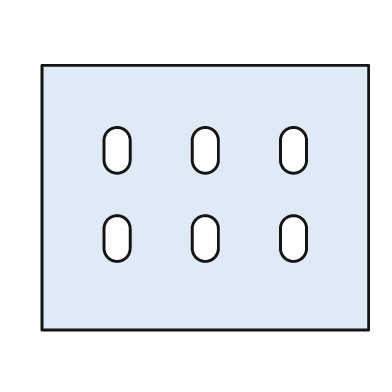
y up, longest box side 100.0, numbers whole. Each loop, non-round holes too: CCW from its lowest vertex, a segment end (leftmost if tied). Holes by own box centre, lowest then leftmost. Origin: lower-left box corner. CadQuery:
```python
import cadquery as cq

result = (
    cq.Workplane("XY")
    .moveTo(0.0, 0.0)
    .lineTo(100.0, 0.0)
    .lineTo(100.0, 81.0)
    .lineTo(0.0, 81.0)
    .close()
    .moveTo(19.0, 25.0)
    .threePointArc((23.0, 21.0), (27.0, 25.0))
    .lineTo(27.0, 31.0)
    .threePointArc((23.0, 35.0), (19.0, 31.0))
    .close()
    .moveTo(46.0, 25.0)
    .threePointArc((50.0, 21.0), (54.0, 25.0))
    .lineTo(54.0, 31.0)
    .threePointArc((50.0, 35.0), (46.0, 31.0))
    .close()
    .moveTo(73.0, 25.0)
    .threePointArc((77.0, 21.0), (81.0, 25.0))
    .lineTo(81.0, 31.0)
    .threePointArc((77.0, 35.0), (73.0, 31.0))
    .close()
    .moveTo(19.0, 52.0)
    .threePointArc((23.0, 48.0), (27.0, 52.0))
    .lineTo(27.0, 58.0)
    .threePointArc((23.0, 62.0), (19.0, 58.0))
    .close()
    .moveTo(46.0, 52.0)
    .threePointArc((50.0, 48.0), (54.0, 52.0))
    .lineTo(54.0, 58.0)
    .threePointArc((50.0, 62.0), (46.0, 58.0))
    .close()
    .moveTo(73.0, 52.0)
    .threePointArc((77.0, 48.0), (81.0, 52.0))
    .lineTo(81.0, 58.0)
    .threePointArc((77.0, 62.0), (73.0, 58.0))
    .close()
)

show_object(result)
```